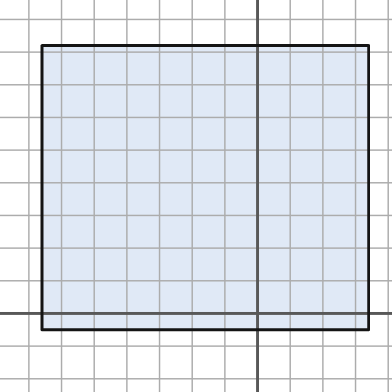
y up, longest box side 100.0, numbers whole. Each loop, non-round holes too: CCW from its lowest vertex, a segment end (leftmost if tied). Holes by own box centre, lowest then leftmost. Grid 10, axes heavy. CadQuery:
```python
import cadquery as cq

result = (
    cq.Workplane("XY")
    .moveTo(-66.0, -5.0)
    .lineTo(34.0, -5.0)
    .lineTo(34.0, 82.0)
    .lineTo(-66.0, 82.0)
    .close()
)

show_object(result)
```